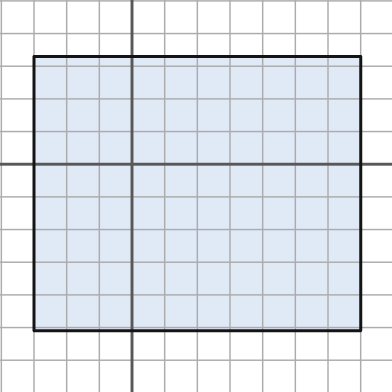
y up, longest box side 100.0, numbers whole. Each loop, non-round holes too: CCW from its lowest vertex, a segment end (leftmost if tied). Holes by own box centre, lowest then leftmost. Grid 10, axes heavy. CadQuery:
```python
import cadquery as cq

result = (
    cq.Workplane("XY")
    .moveTo(-30.0, -51.0)
    .lineTo(70.0, -51.0)
    .lineTo(70.0, 33.0)
    .lineTo(-30.0, 33.0)
    .close()
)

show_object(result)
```